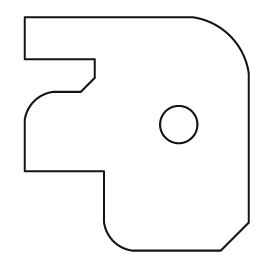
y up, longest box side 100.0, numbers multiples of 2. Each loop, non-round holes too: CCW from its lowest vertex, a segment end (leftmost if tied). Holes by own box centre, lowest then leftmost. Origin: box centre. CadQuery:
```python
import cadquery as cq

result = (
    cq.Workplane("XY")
    .moveTo(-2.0, -50.0)
    .lineTo(36.0, -50.0)
    .lineTo(48.0, -38.0)
    .lineTo(48.0, 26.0)
    .threePointArc((40.0, 42.0), (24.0, 50.0))
    .lineTo(-48.0, 50.0)
    .lineTo(-48.0, 32.0)
    .lineTo(-18.0, 32.0)
    .lineTo(-18.0, 24.0)
    .lineTo(-24.0, 18.0)
    .lineTo(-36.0, 18.0)
    .threePointArc((-44.0, 14.0), (-48.0, 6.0))
    .lineTo(-48.0, -16.0)
    .lineTo(-14.0, -16.0)
    .lineTo(-14.0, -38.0)
    .threePointArc((-10.0, -46.0), (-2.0, -50.0))
    .close()
    .moveTo(18.0, 4.0)
    .circle(8.0)
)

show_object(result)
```